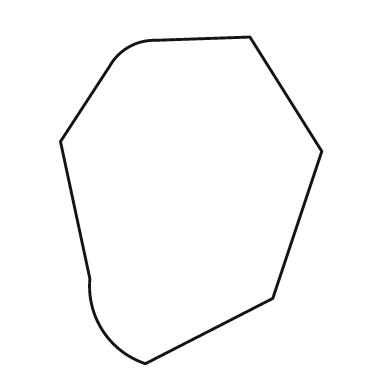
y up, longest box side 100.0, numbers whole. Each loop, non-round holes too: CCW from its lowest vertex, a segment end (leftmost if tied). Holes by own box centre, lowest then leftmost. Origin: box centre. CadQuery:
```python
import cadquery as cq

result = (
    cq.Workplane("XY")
    .moveTo(-14.0, -50.0)
    .lineTo(25.0, -30.0)
    .lineTo(40.0, 15.0)
    .lineTo(18.0, 50.0)
    .lineTo(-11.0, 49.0)
    .threePointArc((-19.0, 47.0), (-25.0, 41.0))
    .lineTo(-40.0, 18.0)
    .lineTo(-31.0, -24.0)
    .threePointArc((-27.0, -40.0), (-14.0, -50.0))
    .close()
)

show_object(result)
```